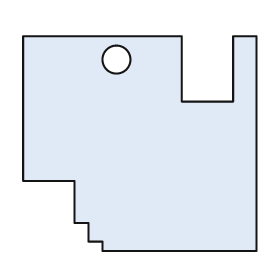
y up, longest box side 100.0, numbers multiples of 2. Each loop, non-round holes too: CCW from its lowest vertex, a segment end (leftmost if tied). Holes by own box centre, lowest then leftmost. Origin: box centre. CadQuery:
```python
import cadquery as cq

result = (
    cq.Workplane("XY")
    .moveTo(-16.0, -46.0)
    .lineTo(50.0, -46.0)
    .lineTo(50.0, 46.0)
    .lineTo(40.0, 46.0)
    .lineTo(40.0, 18.0)
    .lineTo(18.0, 18.0)
    .lineTo(18.0, 46.0)
    .lineTo(-50.0, 46.0)
    .lineTo(-50.0, -16.0)
    .lineTo(-28.0, -16.0)
    .lineTo(-28.0, -34.0)
    .lineTo(-22.0, -34.0)
    .lineTo(-22.0, -42.0)
    .lineTo(-16.0, -42.0)
    .close()
    .moveTo(-10.0, 36.0)
    .circle(6.0)
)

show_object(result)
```